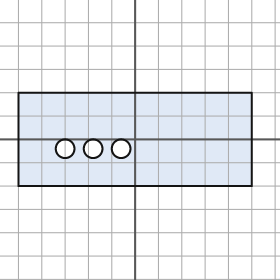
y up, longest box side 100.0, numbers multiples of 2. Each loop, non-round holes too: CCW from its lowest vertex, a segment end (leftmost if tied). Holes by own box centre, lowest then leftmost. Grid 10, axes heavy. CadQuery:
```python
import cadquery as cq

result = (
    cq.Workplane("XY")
    .moveTo(-50.0, -20.0)
    .lineTo(50.0, -20.0)
    .lineTo(50.0, 20.0)
    .lineTo(-50.0, 20.0)
    .close()
    .moveTo(-30.0, -4.0)
    .circle(4.0)
    .moveTo(-18.0, -4.0)
    .circle(4.0)
    .moveTo(-6.0, -4.0)
    .circle(4.0)
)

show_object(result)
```